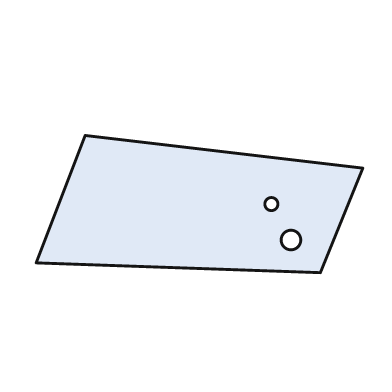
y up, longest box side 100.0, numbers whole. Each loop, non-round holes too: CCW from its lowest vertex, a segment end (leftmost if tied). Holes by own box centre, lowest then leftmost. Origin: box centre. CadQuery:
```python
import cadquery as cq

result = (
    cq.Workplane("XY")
    .moveTo(37.0, -21.0)
    .lineTo(50.0, 11.0)
    .lineTo(-35.0, 21.0)
    .lineTo(-50.0, -18.0)
    .close()
    .moveTo(28.0, -11.0)
    .circle(3.0)
    .moveTo(22.0, 0.0)
    .circle(2.0)
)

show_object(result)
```